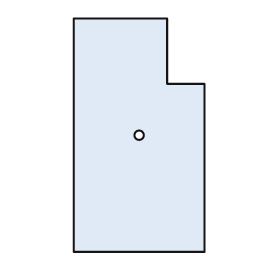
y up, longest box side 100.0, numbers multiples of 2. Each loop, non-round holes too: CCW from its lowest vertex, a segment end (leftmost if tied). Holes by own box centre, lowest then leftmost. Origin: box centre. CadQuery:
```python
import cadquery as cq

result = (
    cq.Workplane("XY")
    .moveTo(-28.0, -50.0)
    .lineTo(28.0, -50.0)
    .lineTo(28.0, 22.0)
    .lineTo(12.0, 22.0)
    .lineTo(12.0, 50.0)
    .lineTo(-28.0, 50.0)
    .close()
    .moveTo(0.0, 0.0)
    .circle(2.0)
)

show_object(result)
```